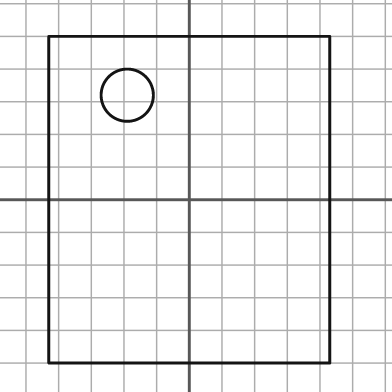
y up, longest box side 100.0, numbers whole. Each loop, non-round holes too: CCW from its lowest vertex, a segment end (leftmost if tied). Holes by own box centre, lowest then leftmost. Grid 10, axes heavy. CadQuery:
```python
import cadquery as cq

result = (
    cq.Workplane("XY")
    .moveTo(-43.0, -50.0)
    .lineTo(43.0, -50.0)
    .lineTo(43.0, 50.0)
    .lineTo(-43.0, 50.0)
    .close()
    .moveTo(-19.0, 32.0)
    .circle(8.0)
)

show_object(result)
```